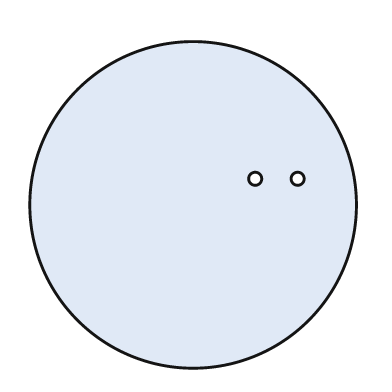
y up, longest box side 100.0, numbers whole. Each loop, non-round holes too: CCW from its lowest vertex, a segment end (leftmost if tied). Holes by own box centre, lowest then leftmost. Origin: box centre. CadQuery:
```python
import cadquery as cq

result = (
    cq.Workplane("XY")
    .moveTo(0.0, 0.0)
    .circle(50.0)
    .moveTo(19.0, 8.0)
    .circle(2.0)
    .moveTo(32.0, 8.0)
    .circle(2.0)
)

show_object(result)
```